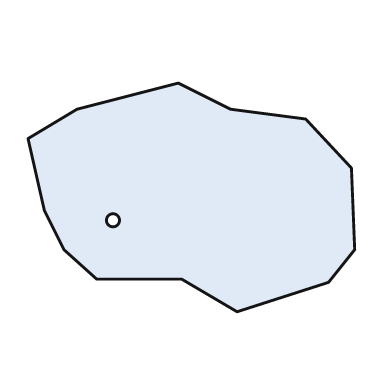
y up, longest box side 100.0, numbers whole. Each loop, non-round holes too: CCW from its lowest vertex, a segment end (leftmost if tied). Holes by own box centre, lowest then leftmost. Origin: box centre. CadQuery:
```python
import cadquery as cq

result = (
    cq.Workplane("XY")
    .moveTo(14.0, -35.0)
    .lineTo(42.0, -26.0)
    .lineTo(50.0, -16.0)
    .lineTo(49.0, 9.0)
    .lineTo(35.0, 24.0)
    .lineTo(12.0, 27.0)
    .lineTo(-4.0, 35.0)
    .lineTo(-35.0, 27.0)
    .lineTo(-50.0, 18.0)
    .lineTo(-45.0, -4.0)
    .lineTo(-39.0, -16.0)
    .lineTo(-29.0, -25.0)
    .lineTo(-3.0, -25.0)
    .close()
    .moveTo(-24.0, -7.0)
    .circle(2.0)
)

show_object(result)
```